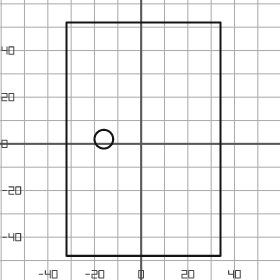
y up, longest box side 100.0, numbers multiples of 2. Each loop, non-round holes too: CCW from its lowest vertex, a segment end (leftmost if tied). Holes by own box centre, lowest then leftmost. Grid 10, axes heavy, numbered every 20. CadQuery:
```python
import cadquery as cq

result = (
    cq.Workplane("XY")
    .moveTo(-32.0, -48.0)
    .lineTo(34.0, -48.0)
    .lineTo(34.0, 52.0)
    .lineTo(-32.0, 52.0)
    .close()
    .moveTo(-16.0, 2.0)
    .circle(4.0)
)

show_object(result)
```